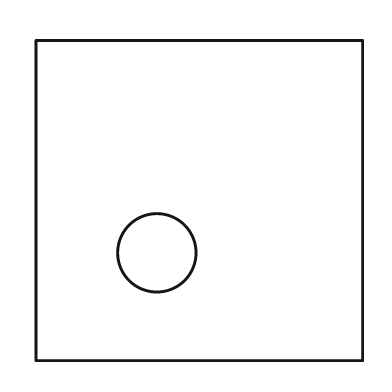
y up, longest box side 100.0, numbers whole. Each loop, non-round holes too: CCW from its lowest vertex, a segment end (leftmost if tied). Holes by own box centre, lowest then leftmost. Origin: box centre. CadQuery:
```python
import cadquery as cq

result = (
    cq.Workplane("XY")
    .moveTo(-50.0, -49.0)
    .lineTo(50.0, -49.0)
    .lineTo(50.0, 49.0)
    .lineTo(-50.0, 49.0)
    .close()
    .moveTo(-13.0, -16.0)
    .circle(12.0)
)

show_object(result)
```